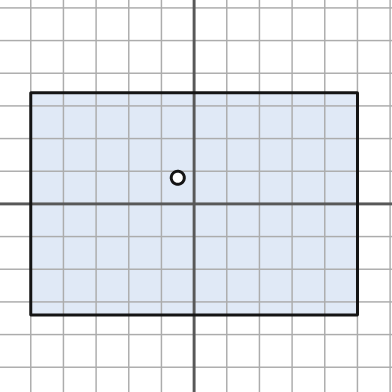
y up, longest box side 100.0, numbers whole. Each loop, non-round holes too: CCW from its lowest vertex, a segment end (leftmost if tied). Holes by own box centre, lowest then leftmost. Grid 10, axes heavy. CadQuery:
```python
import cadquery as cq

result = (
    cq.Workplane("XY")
    .moveTo(-50.0, -34.0)
    .lineTo(50.0, -34.0)
    .lineTo(50.0, 34.0)
    .lineTo(-50.0, 34.0)
    .close()
    .moveTo(-5.0, 8.0)
    .circle(2.0)
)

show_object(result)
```